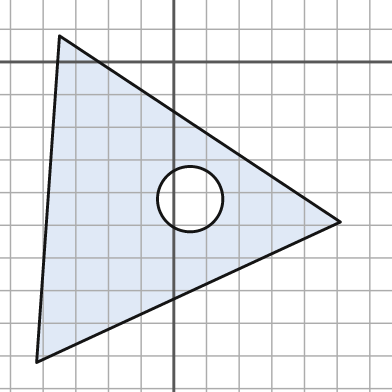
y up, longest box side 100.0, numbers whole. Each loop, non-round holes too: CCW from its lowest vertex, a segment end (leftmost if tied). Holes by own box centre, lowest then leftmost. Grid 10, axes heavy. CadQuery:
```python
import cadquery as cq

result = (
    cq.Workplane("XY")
    .moveTo(-42.0, -92.0)
    .lineTo(51.0, -49.0)
    .lineTo(-35.0, 8.0)
    .close()
    .moveTo(5.0, -42.0)
    .circle(10.0)
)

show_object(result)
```